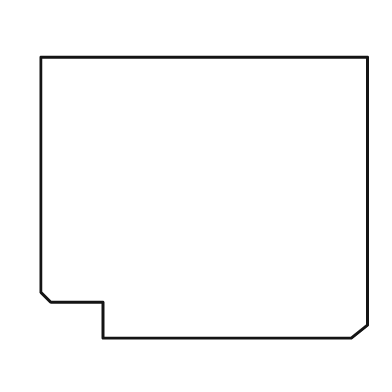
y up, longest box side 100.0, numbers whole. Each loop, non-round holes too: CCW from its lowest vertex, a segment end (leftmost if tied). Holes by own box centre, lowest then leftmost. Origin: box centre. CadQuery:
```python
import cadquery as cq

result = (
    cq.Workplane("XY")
    .moveTo(-31.0, -43.0)
    .lineTo(45.0, -43.0)
    .lineTo(50.0, -39.0)
    .lineTo(50.0, 43.0)
    .lineTo(-50.0, 43.0)
    .lineTo(-50.0, -29.0)
    .lineTo(-47.0, -32.0)
    .lineTo(-31.0, -32.0)
    .close()
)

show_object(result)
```